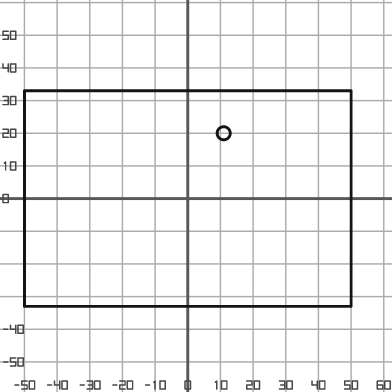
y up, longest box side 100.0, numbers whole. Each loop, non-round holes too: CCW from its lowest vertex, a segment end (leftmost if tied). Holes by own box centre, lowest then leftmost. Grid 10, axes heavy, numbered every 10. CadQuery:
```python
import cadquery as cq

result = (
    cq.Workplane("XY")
    .moveTo(-50.0, -33.0)
    .lineTo(50.0, -33.0)
    .lineTo(50.0, 33.0)
    .lineTo(-50.0, 33.0)
    .close()
    .moveTo(11.0, 20.0)
    .circle(2.0)
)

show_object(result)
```